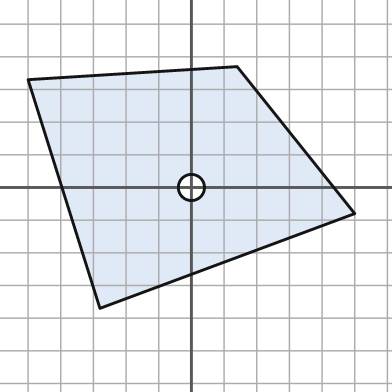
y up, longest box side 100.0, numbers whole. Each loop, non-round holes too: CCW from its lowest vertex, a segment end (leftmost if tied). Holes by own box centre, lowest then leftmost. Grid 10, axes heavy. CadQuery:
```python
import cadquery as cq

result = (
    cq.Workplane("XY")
    .moveTo(-28.0, -37.0)
    .lineTo(50.0, -8.0)
    .lineTo(14.0, 37.0)
    .lineTo(-50.0, 33.0)
    .close()
    .moveTo(0.0, 0.0)
    .circle(4.0)
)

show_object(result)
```